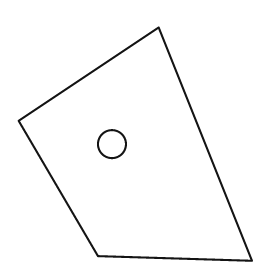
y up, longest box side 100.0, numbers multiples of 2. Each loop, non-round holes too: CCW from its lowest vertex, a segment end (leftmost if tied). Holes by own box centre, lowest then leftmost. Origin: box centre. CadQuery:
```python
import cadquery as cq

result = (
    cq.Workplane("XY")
    .moveTo(50.0, -50.0)
    .lineTo(10.0, 50.0)
    .lineTo(-50.0, 10.0)
    .lineTo(-16.0, -48.0)
    .close()
    .moveTo(-10.0, 0.0)
    .circle(6.0)
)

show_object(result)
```